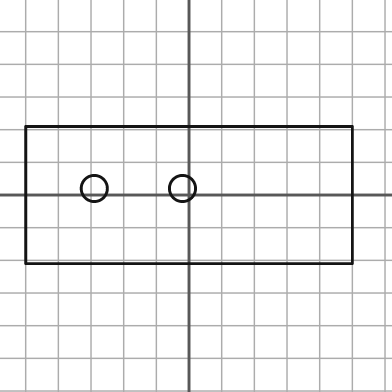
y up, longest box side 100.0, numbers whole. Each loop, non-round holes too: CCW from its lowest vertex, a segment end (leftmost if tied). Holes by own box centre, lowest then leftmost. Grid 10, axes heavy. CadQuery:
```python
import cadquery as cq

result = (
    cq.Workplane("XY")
    .moveTo(-50.0, -21.0)
    .lineTo(50.0, -21.0)
    .lineTo(50.0, 21.0)
    .lineTo(-50.0, 21.0)
    .close()
    .moveTo(-29.0, 2.0)
    .circle(4.0)
    .moveTo(-2.0, 2.0)
    .circle(4.0)
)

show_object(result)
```